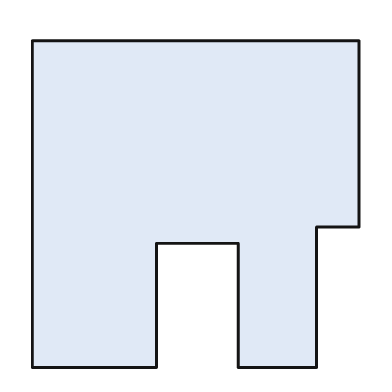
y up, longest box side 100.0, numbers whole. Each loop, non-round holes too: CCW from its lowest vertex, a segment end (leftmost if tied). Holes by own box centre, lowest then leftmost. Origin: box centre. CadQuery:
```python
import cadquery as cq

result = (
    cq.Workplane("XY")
    .moveTo(-50.0, -50.0)
    .lineTo(-12.0, -50.0)
    .lineTo(-12.0, -12.0)
    .lineTo(13.0, -12.0)
    .lineTo(13.0, -50.0)
    .lineTo(37.0, -50.0)
    .lineTo(37.0, -7.0)
    .lineTo(50.0, -7.0)
    .lineTo(50.0, 50.0)
    .lineTo(-50.0, 50.0)
    .close()
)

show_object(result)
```